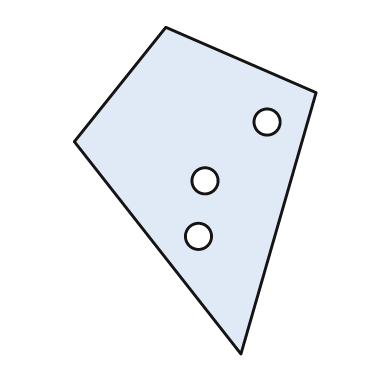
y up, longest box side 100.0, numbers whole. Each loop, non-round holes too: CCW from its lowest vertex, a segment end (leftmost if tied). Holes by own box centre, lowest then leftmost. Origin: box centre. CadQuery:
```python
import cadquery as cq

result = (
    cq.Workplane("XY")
    .moveTo(14.0, -50.0)
    .lineTo(37.0, 30.0)
    .lineTo(-9.0, 50.0)
    .lineTo(-37.0, 15.0)
    .close()
    .moveTo(1.0, -14.0)
    .circle(4.0)
    .moveTo(3.0, 3.0)
    .circle(4.0)
    .moveTo(22.0, 21.0)
    .circle(4.0)
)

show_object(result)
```